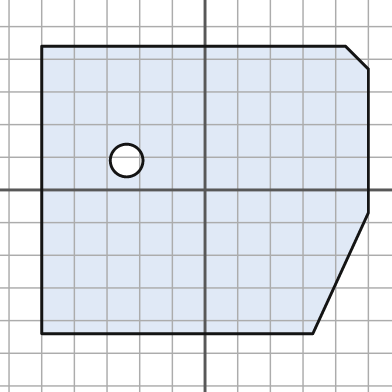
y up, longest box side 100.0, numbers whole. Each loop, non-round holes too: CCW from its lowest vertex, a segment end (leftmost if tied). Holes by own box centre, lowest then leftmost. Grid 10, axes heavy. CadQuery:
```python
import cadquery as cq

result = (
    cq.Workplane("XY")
    .moveTo(-50.0, -44.0)
    .lineTo(33.0, -44.0)
    .lineTo(50.0, -7.0)
    .lineTo(50.0, 37.0)
    .lineTo(43.0, 44.0)
    .lineTo(-50.0, 44.0)
    .close()
    .moveTo(-24.0, 9.0)
    .circle(5.0)
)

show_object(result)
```